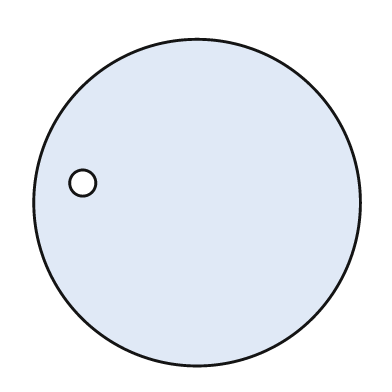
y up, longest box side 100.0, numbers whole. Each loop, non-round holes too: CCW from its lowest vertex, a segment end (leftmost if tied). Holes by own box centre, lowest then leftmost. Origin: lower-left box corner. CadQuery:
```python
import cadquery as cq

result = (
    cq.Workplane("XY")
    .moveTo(50.0, 50.0)
    .circle(50.0)
    .moveTo(15.0, 56.0)
    .circle(4.0)
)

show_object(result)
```